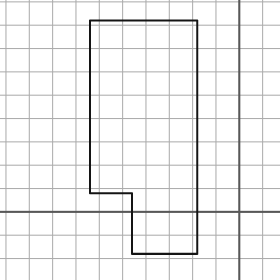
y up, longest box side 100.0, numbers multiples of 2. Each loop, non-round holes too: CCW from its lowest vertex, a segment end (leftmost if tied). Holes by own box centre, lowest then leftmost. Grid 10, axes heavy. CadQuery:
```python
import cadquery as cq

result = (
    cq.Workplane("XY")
    .moveTo(-46.0, -18.0)
    .lineTo(-18.0, -18.0)
    .lineTo(-18.0, 82.0)
    .lineTo(-64.0, 82.0)
    .lineTo(-64.0, 8.0)
    .lineTo(-46.0, 8.0)
    .close()
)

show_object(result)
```